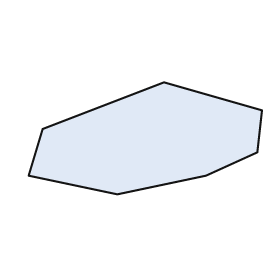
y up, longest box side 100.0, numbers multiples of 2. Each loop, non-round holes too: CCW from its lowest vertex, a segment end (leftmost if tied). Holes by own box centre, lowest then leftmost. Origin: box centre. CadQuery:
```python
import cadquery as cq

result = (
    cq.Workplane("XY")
    .moveTo(-12.0, -24.0)
    .lineTo(26.0, -16.0)
    .lineTo(48.0, -6.0)
    .lineTo(50.0, 12.0)
    .lineTo(8.0, 24.0)
    .lineTo(-44.0, 4.0)
    .lineTo(-50.0, -16.0)
    .close()
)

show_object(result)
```